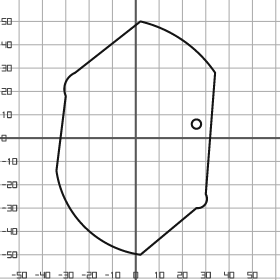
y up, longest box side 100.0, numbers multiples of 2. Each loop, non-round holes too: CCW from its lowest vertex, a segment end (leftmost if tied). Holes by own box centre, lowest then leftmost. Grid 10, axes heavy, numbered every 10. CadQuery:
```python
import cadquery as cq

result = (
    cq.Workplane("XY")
    .moveTo(2.0, -50.0)
    .lineTo(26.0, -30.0)
    .threePointArc((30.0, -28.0), (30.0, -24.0))
    .lineTo(34.0, 28.0)
    .threePointArc((20.0, 42.0), (2.0, 50.0))
    .lineTo(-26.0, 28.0)
    .threePointArc((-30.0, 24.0), (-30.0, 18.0))
    .lineTo(-34.0, -14.0)
    .threePointArc((-22.0, -38.0), (2.0, -50.0))
    .close()
    .moveTo(26.0, 6.0)
    .circle(2.0)
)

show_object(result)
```